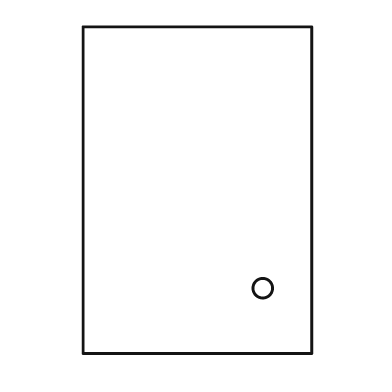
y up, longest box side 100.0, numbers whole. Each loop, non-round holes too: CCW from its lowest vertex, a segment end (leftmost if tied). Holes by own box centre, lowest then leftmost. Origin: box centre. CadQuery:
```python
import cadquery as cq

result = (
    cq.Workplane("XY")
    .moveTo(-35.0, -50.0)
    .lineTo(35.0, -50.0)
    .lineTo(35.0, 50.0)
    .lineTo(-35.0, 50.0)
    .close()
    .moveTo(20.0, -30.0)
    .circle(3.0)
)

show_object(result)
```